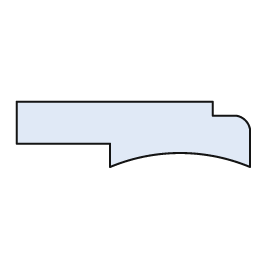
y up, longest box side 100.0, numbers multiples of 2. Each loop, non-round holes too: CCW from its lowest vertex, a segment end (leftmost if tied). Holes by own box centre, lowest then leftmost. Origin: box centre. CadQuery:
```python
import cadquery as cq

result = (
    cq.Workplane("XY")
    .moveTo(-10.0, -14.0)
    .threePointArc((20.0, -8.0), (50.0, -14.0))
    .lineTo(50.0, 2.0)
    .threePointArc((48.0, 6.0), (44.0, 8.0))
    .lineTo(34.0, 8.0)
    .lineTo(34.0, 14.0)
    .lineTo(-50.0, 14.0)
    .lineTo(-50.0, -4.0)
    .lineTo(-10.0, -4.0)
    .close()
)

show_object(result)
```